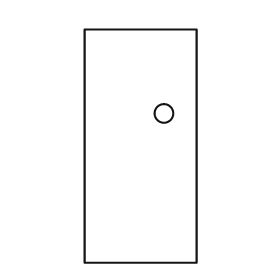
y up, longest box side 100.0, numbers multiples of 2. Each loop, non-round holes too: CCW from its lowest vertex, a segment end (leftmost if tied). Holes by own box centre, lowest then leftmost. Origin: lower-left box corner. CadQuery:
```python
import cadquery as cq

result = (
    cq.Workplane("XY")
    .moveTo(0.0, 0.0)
    .lineTo(48.0, 0.0)
    .lineTo(48.0, 100.0)
    .lineTo(0.0, 100.0)
    .close()
    .moveTo(34.0, 64.0)
    .circle(4.0)
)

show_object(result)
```